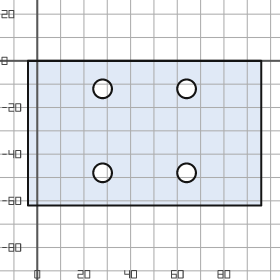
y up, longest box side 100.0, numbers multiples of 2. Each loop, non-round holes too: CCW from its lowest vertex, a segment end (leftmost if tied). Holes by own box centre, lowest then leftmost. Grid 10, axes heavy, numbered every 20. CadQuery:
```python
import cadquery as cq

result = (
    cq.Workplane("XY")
    .moveTo(-4.0, -62.0)
    .lineTo(96.0, -62.0)
    .lineTo(96.0, 0.0)
    .lineTo(-4.0, 0.0)
    .close()
    .moveTo(28.0, -48.0)
    .circle(4.0)
    .moveTo(64.0, -48.0)
    .circle(4.0)
    .moveTo(28.0, -12.0)
    .circle(4.0)
    .moveTo(64.0, -12.0)
    .circle(4.0)
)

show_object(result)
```